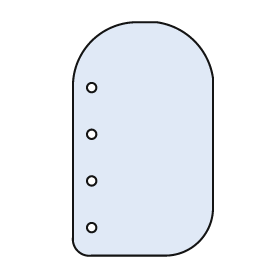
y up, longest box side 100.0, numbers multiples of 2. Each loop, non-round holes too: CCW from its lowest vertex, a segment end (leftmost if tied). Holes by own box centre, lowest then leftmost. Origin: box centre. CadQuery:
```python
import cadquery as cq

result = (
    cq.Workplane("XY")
    .moveTo(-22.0, -50.0)
    .lineTo(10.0, -50.0)
    .threePointArc((24.0, -44.0), (30.0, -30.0))
    .lineTo(30.0, 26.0)
    .threePointArc((22.0, 42.0), (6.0, 50.0))
    .lineTo(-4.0, 50.0)
    .threePointArc((-22.0, 42.0), (-30.0, 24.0))
    .lineTo(-30.0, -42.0)
    .threePointArc((-28.0, -48.0), (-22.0, -50.0))
    .close()
    .moveTo(-22.0, -38.0)
    .circle(2.0)
    .moveTo(-22.0, -18.0)
    .circle(2.0)
    .moveTo(-22.0, 2.0)
    .circle(2.0)
    .moveTo(-22.0, 22.0)
    .circle(2.0)
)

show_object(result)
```